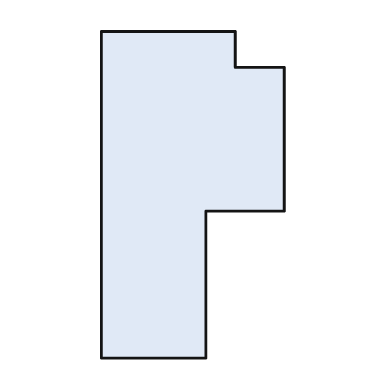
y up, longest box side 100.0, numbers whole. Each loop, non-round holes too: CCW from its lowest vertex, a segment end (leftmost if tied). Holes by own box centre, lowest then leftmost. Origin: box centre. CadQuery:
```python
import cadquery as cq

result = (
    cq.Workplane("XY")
    .moveTo(-28.0, -50.0)
    .lineTo(4.0, -50.0)
    .lineTo(4.0, -5.0)
    .lineTo(28.0, -5.0)
    .lineTo(28.0, 39.0)
    .lineTo(13.0, 39.0)
    .lineTo(13.0, 50.0)
    .lineTo(-28.0, 50.0)
    .close()
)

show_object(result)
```